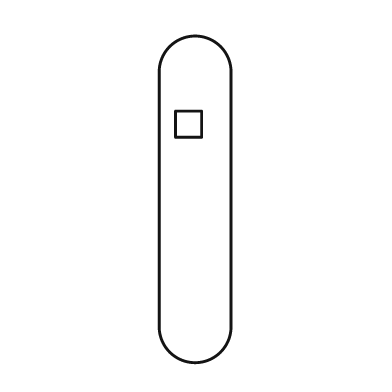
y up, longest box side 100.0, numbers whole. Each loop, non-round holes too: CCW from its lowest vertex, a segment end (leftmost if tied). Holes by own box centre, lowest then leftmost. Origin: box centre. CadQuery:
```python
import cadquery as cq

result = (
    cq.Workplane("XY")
    .moveTo(-11.0, -39.0)
    .threePointArc((0.0, -50.0), (11.0, -39.0))
    .lineTo(11.0, 39.0)
    .threePointArc((0.0, 50.0), (-11.0, 39.0))
    .close()
    .moveTo(-6.0, 19.0)
    .lineTo(2.0, 19.0)
    .lineTo(2.0, 27.0)
    .lineTo(-6.0, 27.0)
    .close()
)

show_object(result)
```